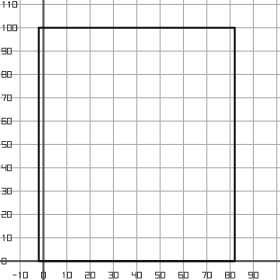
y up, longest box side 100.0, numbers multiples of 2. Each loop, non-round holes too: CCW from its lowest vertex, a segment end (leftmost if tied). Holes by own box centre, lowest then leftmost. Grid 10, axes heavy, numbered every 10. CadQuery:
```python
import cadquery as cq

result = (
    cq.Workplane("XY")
    .moveTo(-2.0, 0.0)
    .lineTo(82.0, 0.0)
    .lineTo(82.0, 100.0)
    .lineTo(-2.0, 100.0)
    .close()
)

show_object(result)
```